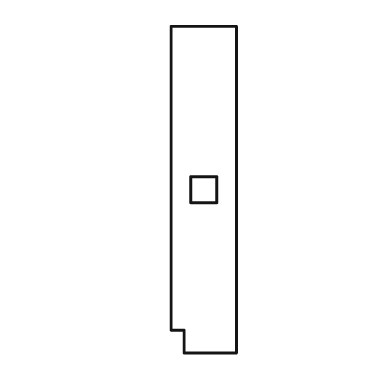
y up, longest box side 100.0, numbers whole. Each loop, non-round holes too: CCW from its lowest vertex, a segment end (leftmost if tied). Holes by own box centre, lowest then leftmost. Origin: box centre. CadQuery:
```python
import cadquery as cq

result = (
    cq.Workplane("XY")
    .moveTo(-6.0, -50.0)
    .lineTo(10.0, -50.0)
    .lineTo(10.0, 50.0)
    .lineTo(-10.0, 50.0)
    .lineTo(-10.0, -43.0)
    .lineTo(-6.0, -43.0)
    .close()
    .moveTo(-4.0, -4.0)
    .lineTo(4.0, -4.0)
    .lineTo(4.0, 4.0)
    .lineTo(-4.0, 4.0)
    .close()
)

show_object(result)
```